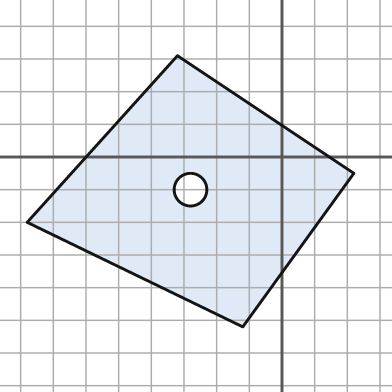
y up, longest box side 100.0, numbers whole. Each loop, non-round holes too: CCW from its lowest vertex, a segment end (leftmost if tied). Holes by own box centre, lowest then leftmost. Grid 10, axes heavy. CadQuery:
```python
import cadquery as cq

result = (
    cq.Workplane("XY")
    .moveTo(-12.0, -52.0)
    .lineTo(22.0, -5.0)
    .lineTo(-32.0, 31.0)
    .lineTo(-78.0, -20.0)
    .close()
    .moveTo(-28.0, -10.0)
    .circle(5.0)
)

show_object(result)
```